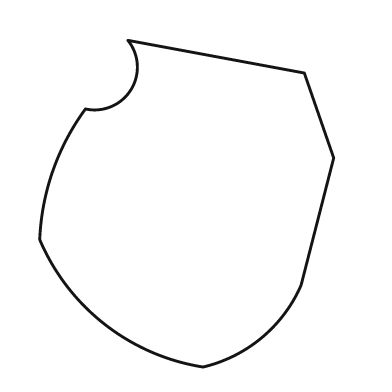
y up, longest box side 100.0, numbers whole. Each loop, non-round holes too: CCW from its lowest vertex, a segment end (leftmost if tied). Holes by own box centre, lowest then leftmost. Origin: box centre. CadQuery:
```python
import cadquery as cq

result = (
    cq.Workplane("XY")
    .moveTo(5.0, -50.0)
    .threePointArc((23.0, -41.0), (35.0, -25.0))
    .lineTo(45.0, 14.0)
    .lineTo(36.0, 40.0)
    .lineTo(-18.0, 50.0)
    .threePointArc((-17.0, 35.0), (-31.0, 29.0))
    .threePointArc((-41.0, 10.0), (-45.0, -11.0))
    .threePointArc((-25.0, -37.0), (5.0, -50.0))
    .close()
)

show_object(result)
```